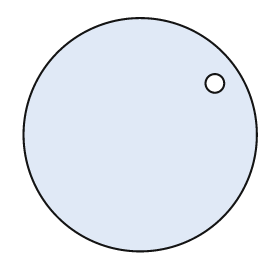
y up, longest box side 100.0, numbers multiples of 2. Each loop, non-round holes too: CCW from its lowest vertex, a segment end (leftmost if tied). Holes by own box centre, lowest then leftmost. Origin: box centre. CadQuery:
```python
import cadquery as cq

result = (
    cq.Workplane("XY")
    .moveTo(0.0, 0.0)
    .circle(50.0)
    .moveTo(32.0, 22.0)
    .circle(4.0)
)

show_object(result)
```